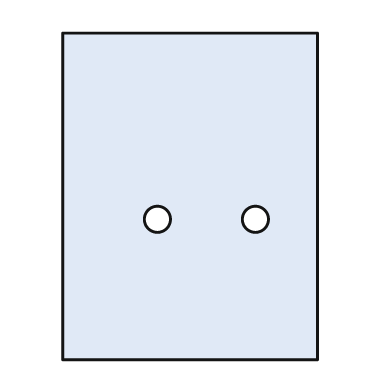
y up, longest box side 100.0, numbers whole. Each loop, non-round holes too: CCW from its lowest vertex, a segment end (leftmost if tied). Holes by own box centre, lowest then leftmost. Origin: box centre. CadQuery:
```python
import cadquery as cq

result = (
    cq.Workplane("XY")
    .moveTo(-39.0, -50.0)
    .lineTo(39.0, -50.0)
    .lineTo(39.0, 50.0)
    .lineTo(-39.0, 50.0)
    .close()
    .moveTo(-10.0, -7.0)
    .circle(4.0)
    .moveTo(20.0, -7.0)
    .circle(4.0)
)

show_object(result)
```